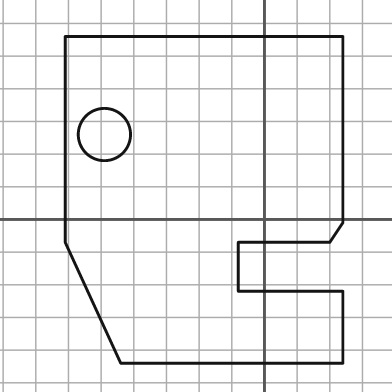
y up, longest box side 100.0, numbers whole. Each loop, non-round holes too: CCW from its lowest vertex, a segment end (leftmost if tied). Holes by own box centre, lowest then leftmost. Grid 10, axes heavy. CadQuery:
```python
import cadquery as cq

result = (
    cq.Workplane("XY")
    .moveTo(-44.0, -44.0)
    .lineTo(24.0, -44.0)
    .lineTo(24.0, -22.0)
    .lineTo(-8.0, -22.0)
    .lineTo(-8.0, -7.0)
    .lineTo(20.0, -7.0)
    .lineTo(24.0, -1.0)
    .lineTo(24.0, 56.0)
    .lineTo(-61.0, 56.0)
    .lineTo(-61.0, -7.0)
    .close()
    .moveTo(-49.0, 26.0)
    .circle(8.0)
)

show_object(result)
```